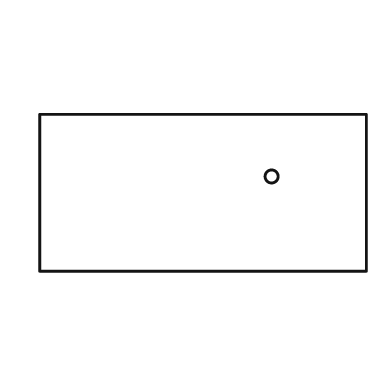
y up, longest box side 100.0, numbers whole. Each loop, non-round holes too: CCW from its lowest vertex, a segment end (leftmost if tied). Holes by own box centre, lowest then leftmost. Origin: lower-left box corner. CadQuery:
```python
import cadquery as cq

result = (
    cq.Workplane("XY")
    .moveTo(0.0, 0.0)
    .lineTo(100.0, 0.0)
    .lineTo(100.0, 48.0)
    .lineTo(0.0, 48.0)
    .close()
    .moveTo(71.0, 29.0)
    .circle(2.0)
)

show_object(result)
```